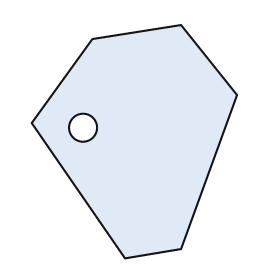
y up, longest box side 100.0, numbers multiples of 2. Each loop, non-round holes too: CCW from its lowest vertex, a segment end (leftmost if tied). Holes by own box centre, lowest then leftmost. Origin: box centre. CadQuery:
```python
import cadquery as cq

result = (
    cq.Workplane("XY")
    .moveTo(-4.0, -50.0)
    .lineTo(20.0, -46.0)
    .lineTo(44.0, 20.0)
    .lineTo(20.0, 50.0)
    .lineTo(-18.0, 44.0)
    .lineTo(-44.0, 8.0)
    .close()
    .moveTo(-22.0, 6.0)
    .circle(6.0)
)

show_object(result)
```